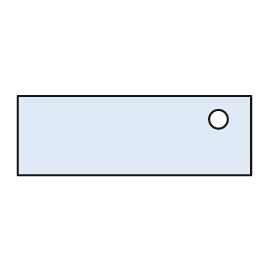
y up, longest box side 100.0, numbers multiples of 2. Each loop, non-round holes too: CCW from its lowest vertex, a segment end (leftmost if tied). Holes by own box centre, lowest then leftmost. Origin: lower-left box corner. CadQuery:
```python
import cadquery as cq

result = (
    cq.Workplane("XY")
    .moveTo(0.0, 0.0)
    .lineTo(100.0, 0.0)
    .lineTo(100.0, 34.0)
    .lineTo(0.0, 34.0)
    .close()
    .moveTo(86.0, 24.0)
    .circle(4.0)
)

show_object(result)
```